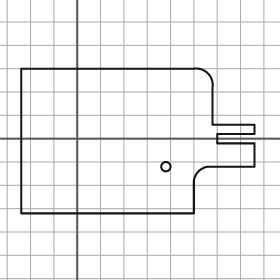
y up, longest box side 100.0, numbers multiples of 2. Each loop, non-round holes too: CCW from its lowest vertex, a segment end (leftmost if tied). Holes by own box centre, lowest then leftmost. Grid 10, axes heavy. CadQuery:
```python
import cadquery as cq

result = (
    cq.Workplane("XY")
    .moveTo(-24.0, -32.0)
    .lineTo(50.0, -32.0)
    .lineTo(50.0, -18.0)
    .threePointArc((52.0, -14.0), (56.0, -12.0))
    .lineTo(76.0, -12.0)
    .lineTo(76.0, -2.0)
    .lineTo(60.0, -2.0)
    .lineTo(60.0, 2.0)
    .lineTo(76.0, 2.0)
    .lineTo(76.0, 6.0)
    .lineTo(58.0, 6.0)
    .lineTo(58.0, 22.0)
    .threePointArc((56.0, 28.0), (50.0, 30.0))
    .lineTo(-24.0, 30.0)
    .close()
    .moveTo(38.0, -12.0)
    .circle(2.0)
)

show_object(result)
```